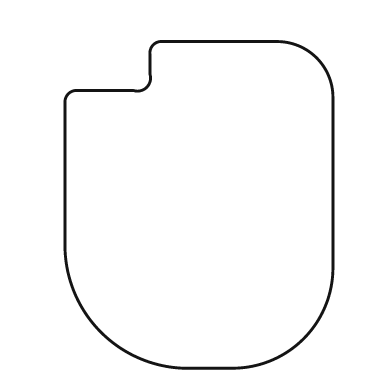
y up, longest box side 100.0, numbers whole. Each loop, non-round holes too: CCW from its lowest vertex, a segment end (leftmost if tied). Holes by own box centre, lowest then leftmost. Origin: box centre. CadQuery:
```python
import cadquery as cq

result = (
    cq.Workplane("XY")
    .moveTo(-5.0, -50.0)
    .lineTo(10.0, -50.0)
    .threePointArc((32.0, -41.0), (41.0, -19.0))
    .lineTo(41.0, 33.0)
    .threePointArc((36.0, 45.0), (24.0, 50.0))
    .lineTo(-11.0, 50.0)
    .threePointArc((-14.0, 49.0), (-15.0, 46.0))
    .lineTo(-15.0, 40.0)
    .threePointArc((-16.0, 36.0), (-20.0, 35.0))
    .lineTo(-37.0, 35.0)
    .threePointArc((-40.0, 34.0), (-41.0, 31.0))
    .lineTo(-41.0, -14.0)
    .threePointArc((-30.0, -39.0), (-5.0, -50.0))
    .close()
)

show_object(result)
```